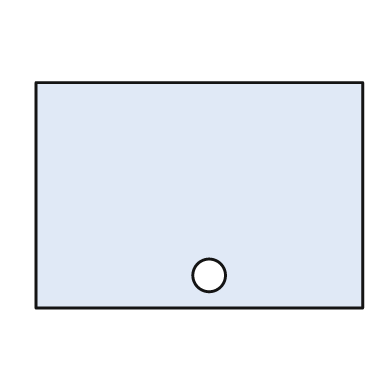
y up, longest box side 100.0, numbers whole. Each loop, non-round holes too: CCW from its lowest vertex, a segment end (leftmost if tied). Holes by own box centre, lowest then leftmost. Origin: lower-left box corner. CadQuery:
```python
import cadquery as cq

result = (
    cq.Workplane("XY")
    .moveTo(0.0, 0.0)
    .lineTo(100.0, 0.0)
    .lineTo(100.0, 69.0)
    .lineTo(0.0, 69.0)
    .close()
    .moveTo(53.0, 10.0)
    .circle(5.0)
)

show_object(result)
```